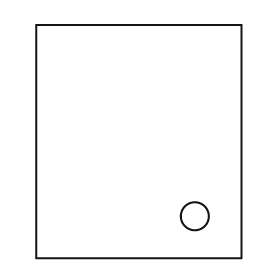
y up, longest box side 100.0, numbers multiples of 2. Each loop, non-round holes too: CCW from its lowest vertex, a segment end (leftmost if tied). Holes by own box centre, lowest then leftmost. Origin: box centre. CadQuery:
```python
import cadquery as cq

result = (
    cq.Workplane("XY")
    .moveTo(-44.0, -50.0)
    .lineTo(44.0, -50.0)
    .lineTo(44.0, 50.0)
    .lineTo(-44.0, 50.0)
    .close()
    .moveTo(24.0, -32.0)
    .circle(6.0)
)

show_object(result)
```